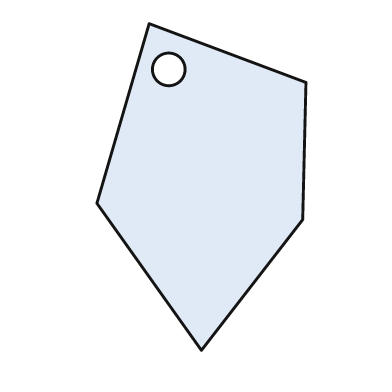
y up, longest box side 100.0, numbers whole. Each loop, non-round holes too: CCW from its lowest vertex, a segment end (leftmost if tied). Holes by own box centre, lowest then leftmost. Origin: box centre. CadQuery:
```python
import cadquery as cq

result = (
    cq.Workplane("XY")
    .moveTo(0.0, -50.0)
    .lineTo(31.0, -10.0)
    .lineTo(32.0, 32.0)
    .lineTo(-16.0, 50.0)
    .lineTo(-32.0, -5.0)
    .close()
    .moveTo(-10.0, 36.0)
    .circle(5.0)
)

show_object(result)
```